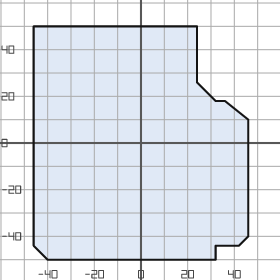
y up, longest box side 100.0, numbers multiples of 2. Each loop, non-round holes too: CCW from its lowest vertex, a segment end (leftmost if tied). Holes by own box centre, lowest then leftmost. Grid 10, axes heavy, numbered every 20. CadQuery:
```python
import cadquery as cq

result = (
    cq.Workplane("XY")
    .moveTo(-40.0, -50.0)
    .lineTo(32.0, -50.0)
    .lineTo(32.0, -44.0)
    .lineTo(42.0, -44.0)
    .lineTo(46.0, -40.0)
    .lineTo(46.0, 10.0)
    .lineTo(36.0, 18.0)
    .lineTo(32.0, 18.0)
    .lineTo(24.0, 26.0)
    .lineTo(24.0, 50.0)
    .lineTo(-46.0, 50.0)
    .lineTo(-46.0, -44.0)
    .close()
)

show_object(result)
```